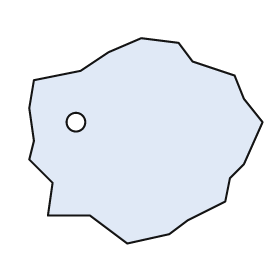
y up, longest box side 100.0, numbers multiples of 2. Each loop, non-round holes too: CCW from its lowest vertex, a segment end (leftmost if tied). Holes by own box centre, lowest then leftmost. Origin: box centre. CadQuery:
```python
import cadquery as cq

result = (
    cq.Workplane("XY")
    .moveTo(-8.0, -44.0)
    .lineTo(10.0, -40.0)
    .lineTo(18.0, -34.0)
    .lineTo(34.0, -26.0)
    .lineTo(36.0, -16.0)
    .lineTo(42.0, -10.0)
    .lineTo(50.0, 8.0)
    .lineTo(42.0, 18.0)
    .lineTo(38.0, 28.0)
    .lineTo(20.0, 34.0)
    .lineTo(14.0, 42.0)
    .lineTo(-2.0, 44.0)
    .lineTo(-16.0, 38.0)
    .lineTo(-28.0, 30.0)
    .lineTo(-48.0, 26.0)
    .lineTo(-50.0, 14.0)
    .lineTo(-48.0, 0.0)
    .lineTo(-50.0, -8.0)
    .lineTo(-40.0, -18.0)
    .lineTo(-42.0, -32.0)
    .lineTo(-24.0, -32.0)
    .close()
    .moveTo(-30.0, 8.0)
    .circle(4.0)
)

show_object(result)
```